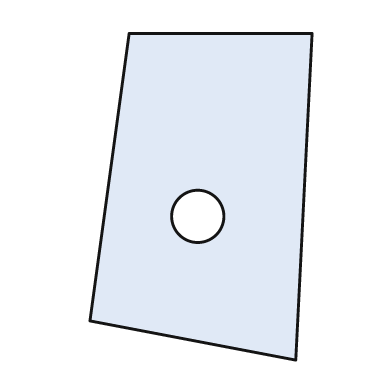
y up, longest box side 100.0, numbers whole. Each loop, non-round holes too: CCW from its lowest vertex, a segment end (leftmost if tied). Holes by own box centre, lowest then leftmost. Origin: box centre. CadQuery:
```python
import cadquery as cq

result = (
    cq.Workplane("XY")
    .moveTo(29.0, -50.0)
    .lineTo(34.0, 50.0)
    .lineTo(-22.0, 50.0)
    .lineTo(-34.0, -38.0)
    .close()
    .moveTo(-1.0, -6.0)
    .circle(8.0)
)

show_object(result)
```